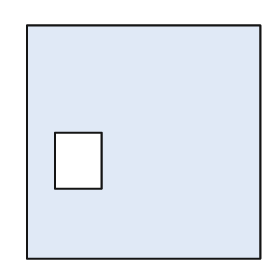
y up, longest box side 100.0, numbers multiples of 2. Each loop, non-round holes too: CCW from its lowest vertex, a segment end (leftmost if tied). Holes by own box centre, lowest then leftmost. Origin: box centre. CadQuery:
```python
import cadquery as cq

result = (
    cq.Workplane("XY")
    .moveTo(-50.0, -50.0)
    .lineTo(50.0, -50.0)
    .lineTo(50.0, 50.0)
    .lineTo(-50.0, 50.0)
    .close()
    .moveTo(-38.0, -20.0)
    .lineTo(-18.0, -20.0)
    .lineTo(-18.0, 4.0)
    .lineTo(-38.0, 4.0)
    .close()
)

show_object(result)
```